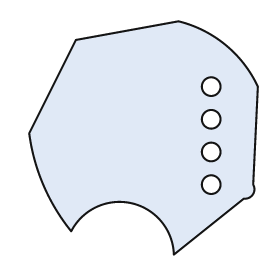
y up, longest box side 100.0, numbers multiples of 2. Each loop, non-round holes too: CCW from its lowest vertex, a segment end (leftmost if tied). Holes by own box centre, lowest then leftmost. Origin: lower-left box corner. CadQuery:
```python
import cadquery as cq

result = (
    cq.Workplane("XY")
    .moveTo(62.0, 0.0)
    .lineTo(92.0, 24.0)
    .threePointArc((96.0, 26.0), (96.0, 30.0))
    .lineTo(98.0, 72.0)
    .threePointArc((84.0, 90.0), (64.0, 100.0))
    .lineTo(20.0, 92.0)
    .lineTo(0.0, 52.0)
    .threePointArc((6.0, 30.0), (18.0, 10.0))
    .threePointArc((44.0, 22.0), (62.0, 0.0))
    .close()
    .moveTo(78.0, 30.0)
    .circle(4.0)
    .moveTo(78.0, 44.0)
    .circle(4.0)
    .moveTo(78.0, 58.0)
    .circle(4.0)
    .moveTo(78.0, 72.0)
    .circle(4.0)
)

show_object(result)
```